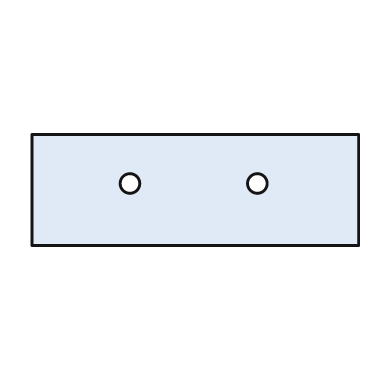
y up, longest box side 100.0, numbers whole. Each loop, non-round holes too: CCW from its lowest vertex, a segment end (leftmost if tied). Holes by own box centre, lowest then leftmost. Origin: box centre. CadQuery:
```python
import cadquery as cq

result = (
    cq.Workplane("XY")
    .moveTo(-50.0, -17.0)
    .lineTo(50.0, -17.0)
    .lineTo(50.0, 17.0)
    .lineTo(-50.0, 17.0)
    .close()
    .moveTo(-20.0, 2.0)
    .circle(3.0)
    .moveTo(19.0, 2.0)
    .circle(3.0)
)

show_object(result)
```